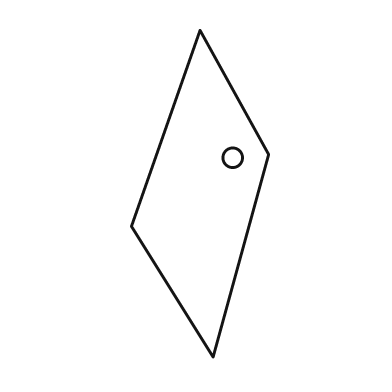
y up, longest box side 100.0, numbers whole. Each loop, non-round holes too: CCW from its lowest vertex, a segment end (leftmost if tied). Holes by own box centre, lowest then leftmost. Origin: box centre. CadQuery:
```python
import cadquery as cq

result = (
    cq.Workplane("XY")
    .moveTo(4.0, -50.0)
    .lineTo(21.0, 12.0)
    .lineTo(0.0, 50.0)
    .lineTo(-21.0, -10.0)
    .close()
    .moveTo(10.0, 11.0)
    .circle(3.0)
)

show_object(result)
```